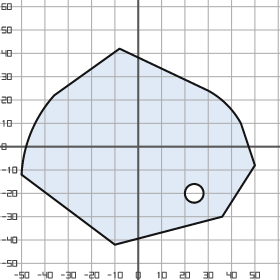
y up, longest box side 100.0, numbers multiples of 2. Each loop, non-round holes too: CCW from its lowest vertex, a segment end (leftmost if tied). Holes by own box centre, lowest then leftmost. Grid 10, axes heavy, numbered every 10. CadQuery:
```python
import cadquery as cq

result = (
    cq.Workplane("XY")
    .moveTo(-10.0, -42.0)
    .lineTo(36.0, -30.0)
    .lineTo(50.0, -8.0)
    .lineTo(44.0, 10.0)
    .threePointArc((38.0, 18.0), (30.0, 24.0))
    .lineTo(-8.0, 42.0)
    .lineTo(-36.0, 22.0)
    .threePointArc((-46.0, 6.0), (-50.0, -12.0))
    .close()
    .moveTo(24.0, -20.0)
    .circle(4.0)
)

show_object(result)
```